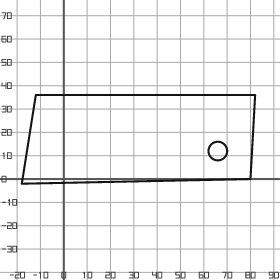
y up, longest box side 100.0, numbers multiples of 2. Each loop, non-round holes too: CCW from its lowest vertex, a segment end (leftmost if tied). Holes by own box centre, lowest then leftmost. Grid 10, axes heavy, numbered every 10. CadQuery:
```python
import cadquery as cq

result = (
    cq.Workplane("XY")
    .moveTo(-18.0, -2.0)
    .lineTo(80.0, 0.0)
    .lineTo(82.0, 36.0)
    .lineTo(-12.0, 36.0)
    .close()
    .moveTo(66.0, 12.0)
    .circle(4.0)
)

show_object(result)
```